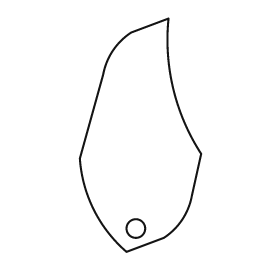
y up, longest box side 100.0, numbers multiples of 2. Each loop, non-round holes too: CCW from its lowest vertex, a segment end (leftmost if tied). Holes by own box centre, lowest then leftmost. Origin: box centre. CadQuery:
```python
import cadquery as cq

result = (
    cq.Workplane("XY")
    .moveTo(-6.0, -50.0)
    .lineTo(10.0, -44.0)
    .threePointArc((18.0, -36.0), (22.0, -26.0))
    .lineTo(26.0, -8.0)
    .threePointArc((14.0, 20.0), (12.0, 50.0))
    .lineTo(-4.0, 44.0)
    .threePointArc((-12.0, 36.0), (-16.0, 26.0))
    .lineTo(-26.0, -10.0)
    .threePointArc((-20.0, -32.0), (-6.0, -50.0))
    .close()
    .moveTo(-2.0, -40.0)
    .circle(4.0)
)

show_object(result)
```